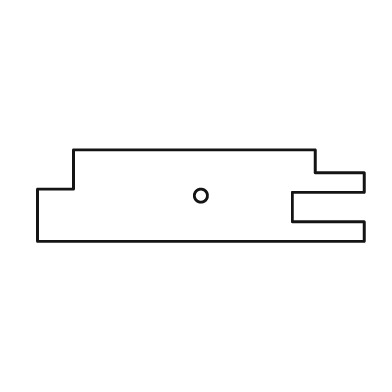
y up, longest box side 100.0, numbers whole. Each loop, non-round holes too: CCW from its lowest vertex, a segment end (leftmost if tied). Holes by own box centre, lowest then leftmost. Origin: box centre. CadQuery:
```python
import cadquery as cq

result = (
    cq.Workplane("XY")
    .moveTo(-50.0, -14.0)
    .lineTo(50.0, -14.0)
    .lineTo(50.0, -8.0)
    .lineTo(28.0, -8.0)
    .lineTo(28.0, 1.0)
    .lineTo(50.0, 1.0)
    .lineTo(50.0, 7.0)
    .lineTo(35.0, 7.0)
    .lineTo(35.0, 14.0)
    .lineTo(-39.0, 14.0)
    .lineTo(-39.0, 2.0)
    .lineTo(-50.0, 2.0)
    .close()
    .moveTo(0.0, 0.0)
    .circle(2.0)
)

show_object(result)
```